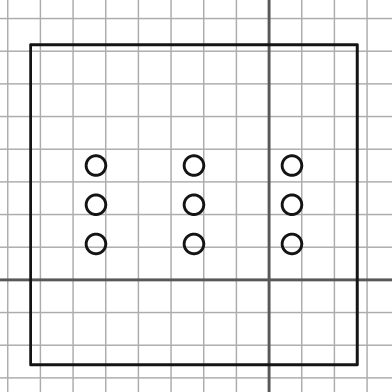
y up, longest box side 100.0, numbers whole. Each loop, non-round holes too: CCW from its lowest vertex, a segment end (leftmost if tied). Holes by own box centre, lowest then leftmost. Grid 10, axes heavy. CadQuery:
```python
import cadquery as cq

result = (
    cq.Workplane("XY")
    .moveTo(-73.0, -26.0)
    .lineTo(27.0, -26.0)
    .lineTo(27.0, 72.0)
    .lineTo(-73.0, 72.0)
    .close()
    .moveTo(-53.0, 11.0)
    .circle(3.0)
    .moveTo(-23.0, 11.0)
    .circle(3.0)
    .moveTo(7.0, 11.0)
    .circle(3.0)
    .moveTo(-53.0, 23.0)
    .circle(3.0)
    .moveTo(-23.0, 23.0)
    .circle(3.0)
    .moveTo(7.0, 23.0)
    .circle(3.0)
    .moveTo(-53.0, 35.0)
    .circle(3.0)
    .moveTo(-23.0, 35.0)
    .circle(3.0)
    .moveTo(7.0, 35.0)
    .circle(3.0)
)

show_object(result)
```